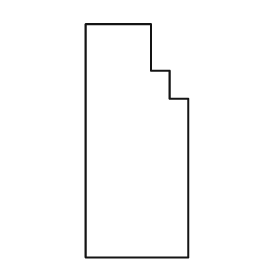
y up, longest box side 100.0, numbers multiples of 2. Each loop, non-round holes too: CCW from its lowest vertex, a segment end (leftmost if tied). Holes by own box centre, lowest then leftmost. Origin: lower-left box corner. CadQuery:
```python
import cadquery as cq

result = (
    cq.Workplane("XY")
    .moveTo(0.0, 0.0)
    .lineTo(44.0, 0.0)
    .lineTo(44.0, 68.0)
    .lineTo(36.0, 68.0)
    .lineTo(36.0, 80.0)
    .lineTo(28.0, 80.0)
    .lineTo(28.0, 100.0)
    .lineTo(0.0, 100.0)
    .close()
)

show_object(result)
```